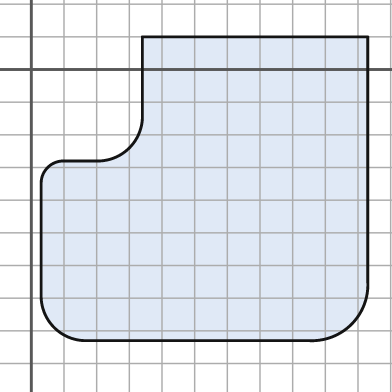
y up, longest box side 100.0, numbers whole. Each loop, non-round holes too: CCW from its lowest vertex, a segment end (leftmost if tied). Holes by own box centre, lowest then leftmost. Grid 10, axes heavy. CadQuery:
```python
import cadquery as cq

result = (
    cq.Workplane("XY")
    .moveTo(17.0, -83.0)
    .lineTo(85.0, -83.0)
    .threePointArc((98.0, -78.0), (103.0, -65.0))
    .lineTo(103.0, 10.0)
    .lineTo(34.0, 10.0)
    .lineTo(34.0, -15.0)
    .threePointArc((30.0, -24.0), (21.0, -28.0))
    .lineTo(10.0, -28.0)
    .threePointArc((5.0, -30.0), (3.0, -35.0))
    .lineTo(3.0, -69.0)
    .threePointArc((7.0, -79.0), (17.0, -83.0))
    .close()
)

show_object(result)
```